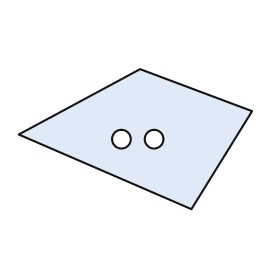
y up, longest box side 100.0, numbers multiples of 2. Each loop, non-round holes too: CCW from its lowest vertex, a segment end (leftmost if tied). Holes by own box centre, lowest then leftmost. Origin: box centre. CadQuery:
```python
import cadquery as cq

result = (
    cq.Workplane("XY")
    .moveTo(24.0, -30.0)
    .lineTo(50.0, 12.0)
    .lineTo(2.0, 30.0)
    .lineTo(-50.0, 2.0)
    .close()
    .moveTo(-6.0, 0.0)
    .circle(4.0)
    .moveTo(8.0, 0.0)
    .circle(4.0)
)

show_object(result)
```